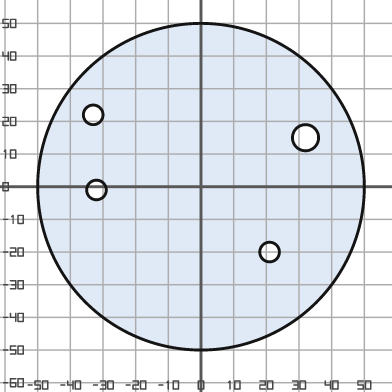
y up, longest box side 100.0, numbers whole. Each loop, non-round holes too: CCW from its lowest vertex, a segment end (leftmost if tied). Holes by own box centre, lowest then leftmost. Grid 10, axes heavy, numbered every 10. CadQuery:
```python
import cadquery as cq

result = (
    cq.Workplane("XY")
    .moveTo(0.0, 0.0)
    .circle(50.0)
    .moveTo(21.0, -20.0)
    .circle(3.0)
    .moveTo(-32.0, -1.0)
    .circle(3.0)
    .moveTo(32.0, 15.0)
    .circle(4.0)
    .moveTo(-33.0, 22.0)
    .circle(3.0)
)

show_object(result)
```